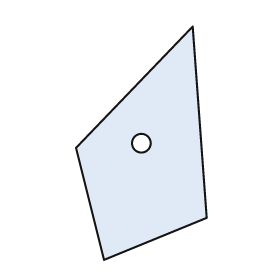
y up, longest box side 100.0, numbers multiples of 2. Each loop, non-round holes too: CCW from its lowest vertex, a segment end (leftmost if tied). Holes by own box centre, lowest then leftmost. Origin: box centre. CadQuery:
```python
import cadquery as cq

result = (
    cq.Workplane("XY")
    .moveTo(-16.0, -50.0)
    .lineTo(28.0, -32.0)
    .lineTo(22.0, 50.0)
    .lineTo(-28.0, -2.0)
    .close()
    .moveTo(0.0, 0.0)
    .circle(4.0)
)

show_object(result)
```